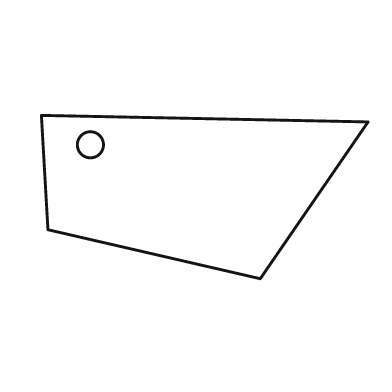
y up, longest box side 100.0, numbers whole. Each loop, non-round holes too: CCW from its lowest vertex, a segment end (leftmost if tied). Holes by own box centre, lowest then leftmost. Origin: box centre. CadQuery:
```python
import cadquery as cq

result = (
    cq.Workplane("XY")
    .moveTo(17.0, -25.0)
    .lineTo(50.0, 23.0)
    .lineTo(-50.0, 25.0)
    .lineTo(-48.0, -10.0)
    .close()
    .moveTo(-35.0, 16.0)
    .circle(4.0)
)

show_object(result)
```